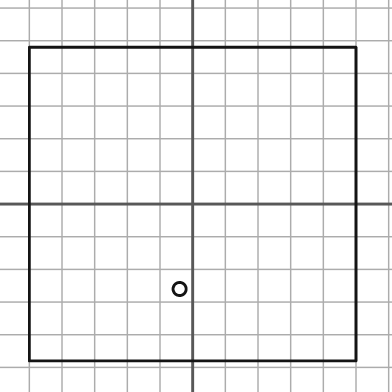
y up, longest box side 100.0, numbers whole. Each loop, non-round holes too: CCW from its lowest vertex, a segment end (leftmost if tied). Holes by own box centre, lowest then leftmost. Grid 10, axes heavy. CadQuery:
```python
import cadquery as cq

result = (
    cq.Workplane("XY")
    .moveTo(-50.0, -48.0)
    .lineTo(50.0, -48.0)
    .lineTo(50.0, 48.0)
    .lineTo(-50.0, 48.0)
    .close()
    .moveTo(-4.0, -26.0)
    .circle(2.0)
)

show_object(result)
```